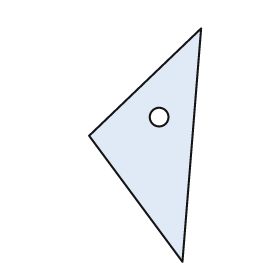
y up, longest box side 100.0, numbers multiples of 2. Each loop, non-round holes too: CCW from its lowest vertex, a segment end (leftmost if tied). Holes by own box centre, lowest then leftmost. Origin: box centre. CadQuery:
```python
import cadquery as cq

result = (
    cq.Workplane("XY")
    .moveTo(16.0, -50.0)
    .lineTo(24.0, 50.0)
    .lineTo(-24.0, 4.0)
    .close()
    .moveTo(6.0, 12.0)
    .circle(4.0)
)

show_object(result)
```